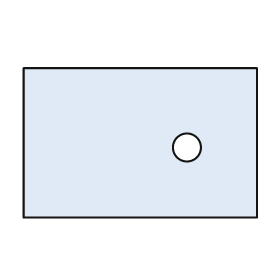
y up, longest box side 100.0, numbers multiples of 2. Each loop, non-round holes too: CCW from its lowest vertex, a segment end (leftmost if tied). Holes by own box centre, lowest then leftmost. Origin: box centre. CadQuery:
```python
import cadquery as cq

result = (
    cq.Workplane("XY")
    .moveTo(-50.0, -32.0)
    .lineTo(50.0, -32.0)
    .lineTo(50.0, 32.0)
    .lineTo(-50.0, 32.0)
    .close()
    .moveTo(20.0, -2.0)
    .circle(6.0)
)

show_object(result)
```